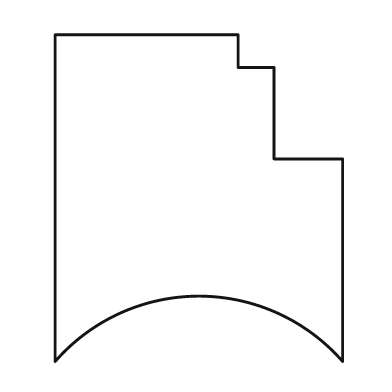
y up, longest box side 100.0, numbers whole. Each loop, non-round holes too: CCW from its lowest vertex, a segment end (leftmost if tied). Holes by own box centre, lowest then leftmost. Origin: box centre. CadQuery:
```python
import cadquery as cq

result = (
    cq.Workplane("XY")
    .moveTo(-44.0, -50.0)
    .threePointArc((0.0, -30.0), (44.0, -50.0))
    .lineTo(44.0, 12.0)
    .lineTo(23.0, 12.0)
    .lineTo(23.0, 40.0)
    .lineTo(12.0, 40.0)
    .lineTo(12.0, 50.0)
    .lineTo(-44.0, 50.0)
    .close()
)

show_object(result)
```